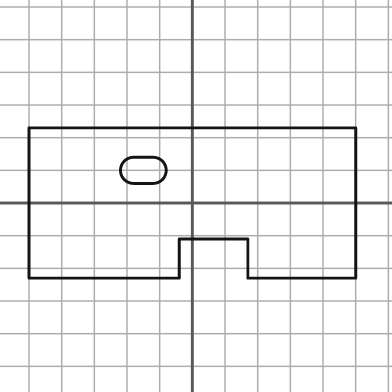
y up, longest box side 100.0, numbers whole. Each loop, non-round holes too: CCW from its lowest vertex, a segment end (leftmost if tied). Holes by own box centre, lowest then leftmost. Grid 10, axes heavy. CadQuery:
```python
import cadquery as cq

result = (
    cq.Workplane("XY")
    .moveTo(-50.0, -23.0)
    .lineTo(-4.0, -23.0)
    .lineTo(-4.0, -11.0)
    .lineTo(17.0, -11.0)
    .lineTo(17.0, -23.0)
    .lineTo(50.0, -23.0)
    .lineTo(50.0, 23.0)
    .lineTo(-50.0, 23.0)
    .close()
    .moveTo(-18.0, 6.0)
    .lineTo(-12.0, 6.0)
    .threePointArc((-8.0, 10.0), (-12.0, 14.0))
    .lineTo(-18.0, 14.0)
    .threePointArc((-22.0, 10.0), (-18.0, 6.0))
    .close()
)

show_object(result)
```